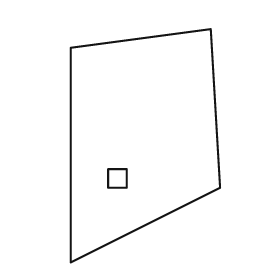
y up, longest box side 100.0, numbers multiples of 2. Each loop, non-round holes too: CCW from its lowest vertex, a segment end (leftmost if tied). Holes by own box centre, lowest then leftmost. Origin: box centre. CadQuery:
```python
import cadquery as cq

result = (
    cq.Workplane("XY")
    .moveTo(-32.0, -50.0)
    .lineTo(32.0, -18.0)
    .lineTo(28.0, 50.0)
    .lineTo(-32.0, 42.0)
    .close()
    .moveTo(-16.0, -18.0)
    .lineTo(-8.0, -18.0)
    .lineTo(-8.0, -10.0)
    .lineTo(-16.0, -10.0)
    .close()
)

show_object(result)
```